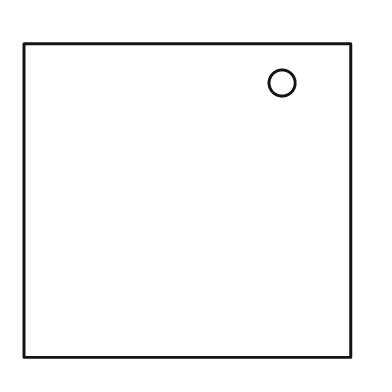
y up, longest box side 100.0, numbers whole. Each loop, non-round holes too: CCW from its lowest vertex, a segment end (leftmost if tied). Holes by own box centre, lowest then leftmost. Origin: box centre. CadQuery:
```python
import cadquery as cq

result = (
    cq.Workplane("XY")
    .moveTo(-50.0, -48.0)
    .lineTo(50.0, -48.0)
    .lineTo(50.0, 48.0)
    .lineTo(-50.0, 48.0)
    .close()
    .moveTo(29.0, 36.0)
    .circle(4.0)
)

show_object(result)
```